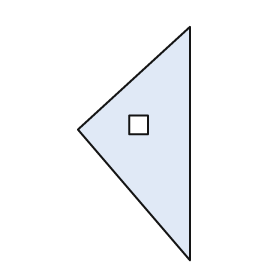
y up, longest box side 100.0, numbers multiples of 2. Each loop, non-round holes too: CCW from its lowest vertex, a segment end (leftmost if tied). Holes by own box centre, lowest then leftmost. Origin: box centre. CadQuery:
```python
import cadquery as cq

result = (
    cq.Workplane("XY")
    .moveTo(24.0, -50.0)
    .lineTo(24.0, 50.0)
    .lineTo(-24.0, 6.0)
    .close()
    .moveTo(-2.0, 4.0)
    .lineTo(6.0, 4.0)
    .lineTo(6.0, 12.0)
    .lineTo(-2.0, 12.0)
    .close()
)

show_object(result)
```